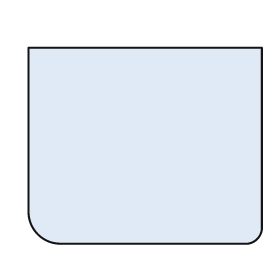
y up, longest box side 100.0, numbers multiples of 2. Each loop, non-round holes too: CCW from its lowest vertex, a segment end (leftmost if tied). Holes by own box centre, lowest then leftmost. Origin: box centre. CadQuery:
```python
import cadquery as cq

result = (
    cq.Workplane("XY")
    .moveTo(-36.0, -42.0)
    .lineTo(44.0, -42.0)
    .threePointArc((48.0, -40.0), (50.0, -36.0))
    .lineTo(50.0, 42.0)
    .lineTo(-50.0, 42.0)
    .lineTo(-50.0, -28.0)
    .threePointArc((-46.0, -38.0), (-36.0, -42.0))
    .close()
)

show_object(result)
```